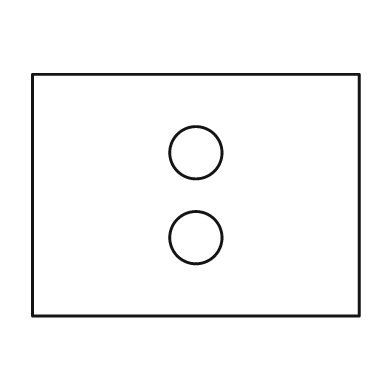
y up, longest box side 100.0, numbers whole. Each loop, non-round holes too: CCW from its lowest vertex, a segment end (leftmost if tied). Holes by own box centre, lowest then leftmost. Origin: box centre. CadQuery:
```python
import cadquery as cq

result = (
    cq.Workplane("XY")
    .moveTo(-50.0, -37.0)
    .lineTo(50.0, -37.0)
    .lineTo(50.0, 37.0)
    .lineTo(-50.0, 37.0)
    .close()
    .moveTo(0.0, -13.0)
    .circle(8.0)
    .moveTo(0.0, 13.0)
    .circle(8.0)
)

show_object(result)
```